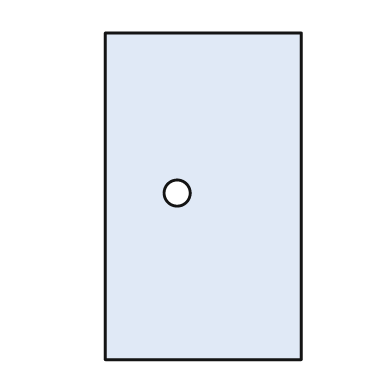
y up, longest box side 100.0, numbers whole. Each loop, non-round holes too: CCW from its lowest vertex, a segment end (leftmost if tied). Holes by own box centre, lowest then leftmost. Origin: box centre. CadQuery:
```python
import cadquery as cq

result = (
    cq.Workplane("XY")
    .moveTo(-30.0, -50.0)
    .lineTo(30.0, -50.0)
    .lineTo(30.0, 50.0)
    .lineTo(-30.0, 50.0)
    .close()
    .moveTo(-8.0, 1.0)
    .circle(4.0)
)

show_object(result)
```